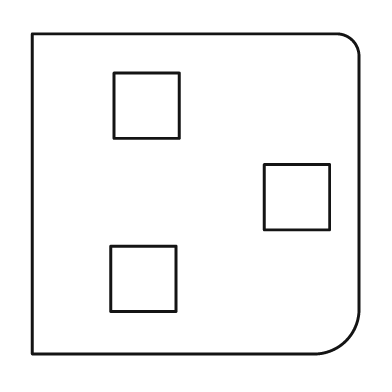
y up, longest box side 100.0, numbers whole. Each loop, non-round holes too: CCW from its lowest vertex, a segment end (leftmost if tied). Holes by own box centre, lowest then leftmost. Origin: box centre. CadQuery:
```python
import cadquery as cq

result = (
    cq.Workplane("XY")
    .moveTo(-50.0, -49.0)
    .lineTo(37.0, -49.0)
    .threePointArc((46.0, -45.0), (50.0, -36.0))
    .lineTo(50.0, 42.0)
    .threePointArc((48.0, 47.0), (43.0, 49.0))
    .lineTo(-50.0, 49.0)
    .close()
    .moveTo(-26.0, -36.0)
    .lineTo(-6.0, -36.0)
    .lineTo(-6.0, -16.0)
    .lineTo(-26.0, -16.0)
    .close()
    .moveTo(21.0, -11.0)
    .lineTo(41.0, -11.0)
    .lineTo(41.0, 9.0)
    .lineTo(21.0, 9.0)
    .close()
    .moveTo(-25.0, 17.0)
    .lineTo(-5.0, 17.0)
    .lineTo(-5.0, 37.0)
    .lineTo(-25.0, 37.0)
    .close()
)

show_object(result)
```